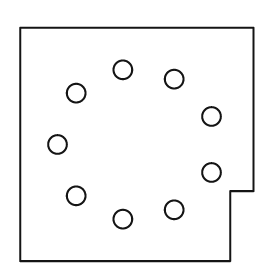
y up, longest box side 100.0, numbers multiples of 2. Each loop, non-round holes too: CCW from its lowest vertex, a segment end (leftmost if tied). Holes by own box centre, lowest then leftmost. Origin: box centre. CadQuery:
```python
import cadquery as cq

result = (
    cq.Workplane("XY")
    .moveTo(-50.0, -50.0)
    .lineTo(40.0, -50.0)
    .lineTo(40.0, -20.0)
    .lineTo(50.0, -20.0)
    .lineTo(50.0, 50.0)
    .lineTo(-50.0, 50.0)
    .close()
    .moveTo(-6.0, -32.0)
    .circle(4.0)
    .moveTo(16.0, -28.0)
    .circle(4.0)
    .moveTo(-26.0, -22.0)
    .circle(4.0)
    .moveTo(32.0, -12.0)
    .circle(4.0)
    .moveTo(-34.0, 0.0)
    .circle(4.0)
    .moveTo(32.0, 12.0)
    .circle(4.0)
    .moveTo(-26.0, 22.0)
    .circle(4.0)
    .moveTo(16.0, 28.0)
    .circle(4.0)
    .moveTo(-6.0, 32.0)
    .circle(4.0)
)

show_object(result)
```